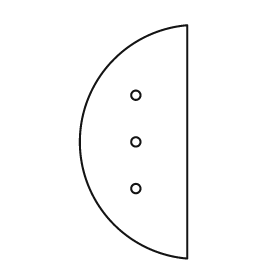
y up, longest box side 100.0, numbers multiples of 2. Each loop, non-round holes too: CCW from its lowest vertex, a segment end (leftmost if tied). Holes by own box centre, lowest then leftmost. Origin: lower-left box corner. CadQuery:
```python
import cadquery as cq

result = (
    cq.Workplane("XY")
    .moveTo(46.0, 0.0)
    .lineTo(46.0, 100.0)
    .threePointArc((0.0, 50.0), (46.0, 0.0))
    .close()
    .moveTo(24.0, 30.0)
    .circle(2.0)
    .moveTo(24.0, 50.0)
    .circle(2.0)
    .moveTo(24.0, 70.0)
    .circle(2.0)
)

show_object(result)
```